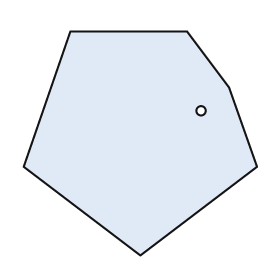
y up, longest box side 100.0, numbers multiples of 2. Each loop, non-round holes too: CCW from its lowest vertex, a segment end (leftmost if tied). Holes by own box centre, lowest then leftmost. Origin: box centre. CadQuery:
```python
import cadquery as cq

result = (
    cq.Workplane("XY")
    .moveTo(0.0, -48.0)
    .lineTo(50.0, -10.0)
    .lineTo(38.0, 24.0)
    .lineTo(20.0, 48.0)
    .lineTo(-30.0, 48.0)
    .lineTo(-50.0, -10.0)
    .close()
    .moveTo(26.0, 14.0)
    .circle(2.0)
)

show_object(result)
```